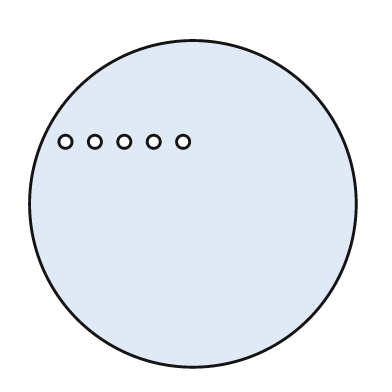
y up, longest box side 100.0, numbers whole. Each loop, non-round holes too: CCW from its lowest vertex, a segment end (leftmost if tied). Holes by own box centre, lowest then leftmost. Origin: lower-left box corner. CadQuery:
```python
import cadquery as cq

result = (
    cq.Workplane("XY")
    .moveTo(50.0, 50.0)
    .circle(50.0)
    .moveTo(11.0, 69.0)
    .circle(2.0)
    .moveTo(20.0, 69.0)
    .circle(2.0)
    .moveTo(29.0, 69.0)
    .circle(2.0)
    .moveTo(38.0, 69.0)
    .circle(2.0)
    .moveTo(47.0, 69.0)
    .circle(2.0)
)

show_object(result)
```